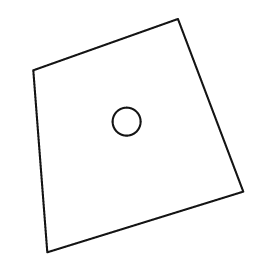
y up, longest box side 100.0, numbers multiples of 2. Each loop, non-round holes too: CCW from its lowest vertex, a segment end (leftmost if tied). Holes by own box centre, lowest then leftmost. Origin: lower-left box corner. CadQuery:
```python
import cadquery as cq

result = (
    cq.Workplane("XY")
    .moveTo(6.0, 0.0)
    .lineTo(90.0, 26.0)
    .lineTo(62.0, 100.0)
    .lineTo(0.0, 78.0)
    .close()
    .moveTo(40.0, 56.0)
    .circle(6.0)
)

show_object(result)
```